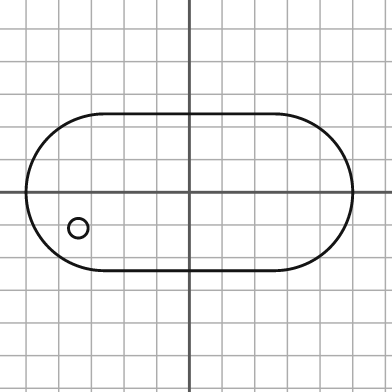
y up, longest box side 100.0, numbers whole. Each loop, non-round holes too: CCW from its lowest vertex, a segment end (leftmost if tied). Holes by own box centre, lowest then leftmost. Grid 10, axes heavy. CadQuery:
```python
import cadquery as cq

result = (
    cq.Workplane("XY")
    .moveTo(-26.0, -24.0)
    .lineTo(26.0, -24.0)
    .threePointArc((50.0, 0.0), (26.0, 24.0))
    .lineTo(-26.0, 24.0)
    .threePointArc((-50.0, 0.0), (-26.0, -24.0))
    .close()
    .moveTo(-34.0, -11.0)
    .circle(3.0)
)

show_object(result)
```